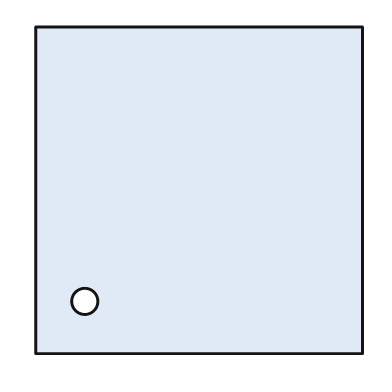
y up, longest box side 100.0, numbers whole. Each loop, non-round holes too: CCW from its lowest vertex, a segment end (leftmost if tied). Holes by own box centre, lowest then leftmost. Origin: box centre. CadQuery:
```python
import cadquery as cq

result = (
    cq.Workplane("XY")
    .moveTo(-50.0, -50.0)
    .lineTo(50.0, -50.0)
    .lineTo(50.0, 50.0)
    .lineTo(-50.0, 50.0)
    .close()
    .moveTo(-35.0, -34.0)
    .circle(4.0)
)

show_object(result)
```